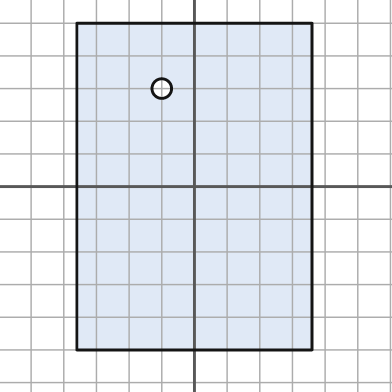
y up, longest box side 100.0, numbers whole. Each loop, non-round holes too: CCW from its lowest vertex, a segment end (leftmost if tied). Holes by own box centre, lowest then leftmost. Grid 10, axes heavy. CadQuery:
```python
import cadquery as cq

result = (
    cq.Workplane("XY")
    .moveTo(-36.0, -50.0)
    .lineTo(36.0, -50.0)
    .lineTo(36.0, 50.0)
    .lineTo(-36.0, 50.0)
    .close()
    .moveTo(-10.0, 30.0)
    .circle(3.0)
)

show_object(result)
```